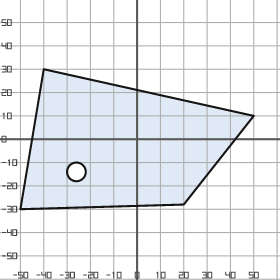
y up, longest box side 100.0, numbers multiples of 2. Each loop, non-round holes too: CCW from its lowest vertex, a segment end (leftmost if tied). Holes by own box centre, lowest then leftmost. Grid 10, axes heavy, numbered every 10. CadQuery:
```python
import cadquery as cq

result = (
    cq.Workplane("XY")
    .moveTo(-50.0, -30.0)
    .lineTo(20.0, -28.0)
    .lineTo(50.0, 10.0)
    .lineTo(-40.0, 30.0)
    .close()
    .moveTo(-26.0, -14.0)
    .circle(4.0)
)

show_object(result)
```